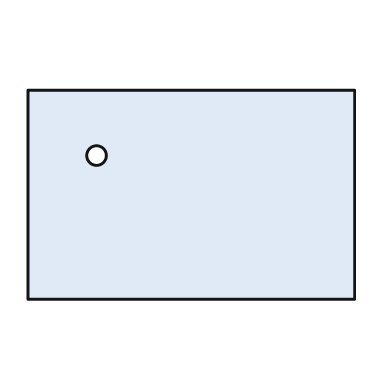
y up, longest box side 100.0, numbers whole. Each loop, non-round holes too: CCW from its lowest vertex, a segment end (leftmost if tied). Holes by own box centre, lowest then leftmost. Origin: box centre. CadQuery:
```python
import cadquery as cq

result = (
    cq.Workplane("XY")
    .moveTo(-50.0, -32.0)
    .lineTo(50.0, -32.0)
    .lineTo(50.0, 32.0)
    .lineTo(-50.0, 32.0)
    .close()
    .moveTo(-29.0, 12.0)
    .circle(3.0)
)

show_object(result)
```